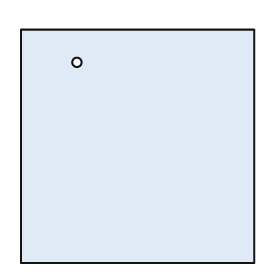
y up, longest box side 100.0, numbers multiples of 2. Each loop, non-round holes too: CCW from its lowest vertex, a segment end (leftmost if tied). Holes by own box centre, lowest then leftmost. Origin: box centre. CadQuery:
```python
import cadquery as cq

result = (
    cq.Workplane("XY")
    .moveTo(-50.0, -50.0)
    .lineTo(50.0, -50.0)
    .lineTo(50.0, 50.0)
    .lineTo(-50.0, 50.0)
    .close()
    .moveTo(-26.0, 36.0)
    .circle(2.0)
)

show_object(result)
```